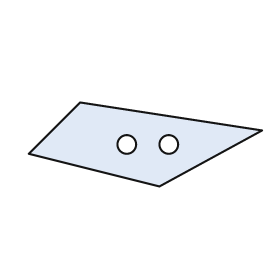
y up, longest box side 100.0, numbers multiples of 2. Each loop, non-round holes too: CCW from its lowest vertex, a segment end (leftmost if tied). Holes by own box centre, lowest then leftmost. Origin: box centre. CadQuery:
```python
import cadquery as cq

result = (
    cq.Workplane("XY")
    .moveTo(6.0, -18.0)
    .lineTo(50.0, 6.0)
    .lineTo(-28.0, 18.0)
    .lineTo(-50.0, -4.0)
    .close()
    .moveTo(-8.0, 0.0)
    .circle(4.0)
    .moveTo(10.0, 0.0)
    .circle(4.0)
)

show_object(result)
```